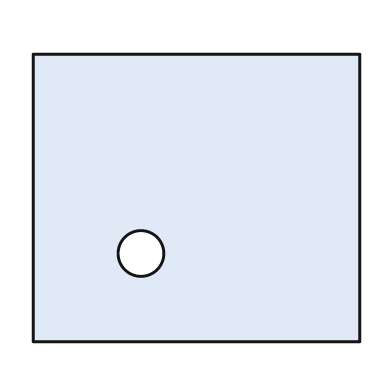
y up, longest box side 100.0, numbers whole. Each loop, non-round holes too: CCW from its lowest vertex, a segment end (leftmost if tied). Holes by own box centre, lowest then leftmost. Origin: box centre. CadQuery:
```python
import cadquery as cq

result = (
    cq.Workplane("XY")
    .moveTo(-50.0, -44.0)
    .lineTo(50.0, -44.0)
    .lineTo(50.0, 44.0)
    .lineTo(-50.0, 44.0)
    .close()
    .moveTo(-17.0, -17.0)
    .circle(7.0)
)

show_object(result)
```